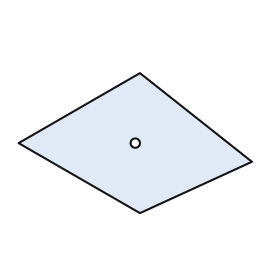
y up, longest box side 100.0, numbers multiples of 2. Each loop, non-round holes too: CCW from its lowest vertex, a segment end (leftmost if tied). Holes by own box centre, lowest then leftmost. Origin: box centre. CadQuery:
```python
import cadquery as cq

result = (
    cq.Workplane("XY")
    .moveTo(2.0, -30.0)
    .lineTo(50.0, -8.0)
    .lineTo(2.0, 30.0)
    .lineTo(-50.0, 0.0)
    .close()
    .moveTo(0.0, 0.0)
    .circle(2.0)
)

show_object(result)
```